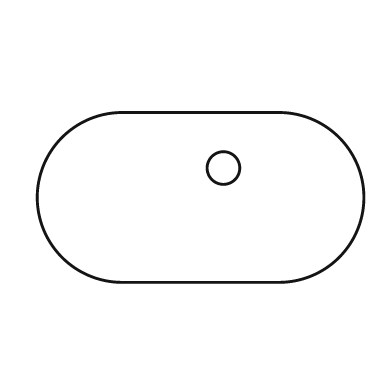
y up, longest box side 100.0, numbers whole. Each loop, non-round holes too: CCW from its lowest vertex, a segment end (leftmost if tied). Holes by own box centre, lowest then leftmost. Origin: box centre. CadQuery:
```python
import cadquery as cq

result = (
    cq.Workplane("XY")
    .moveTo(-24.0, -26.0)
    .lineTo(24.0, -26.0)
    .threePointArc((50.0, 0.0), (24.0, 26.0))
    .lineTo(-24.0, 26.0)
    .threePointArc((-50.0, 0.0), (-24.0, -26.0))
    .close()
    .moveTo(7.0, 9.0)
    .circle(5.0)
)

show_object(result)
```